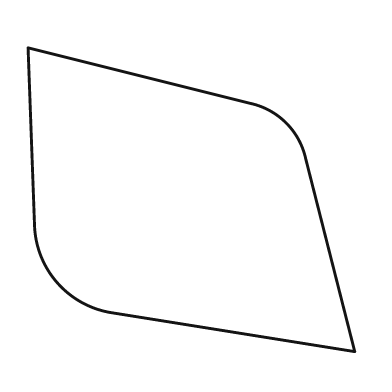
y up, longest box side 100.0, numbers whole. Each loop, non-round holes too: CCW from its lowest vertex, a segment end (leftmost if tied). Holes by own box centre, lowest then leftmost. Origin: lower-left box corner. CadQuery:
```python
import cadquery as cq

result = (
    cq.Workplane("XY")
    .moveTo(100.0, 0.0)
    .lineTo(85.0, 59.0)
    .threePointArc((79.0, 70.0), (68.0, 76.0))
    .lineTo(0.0, 93.0)
    .lineTo(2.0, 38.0)
    .threePointArc((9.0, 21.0), (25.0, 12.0))
    .close()
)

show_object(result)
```